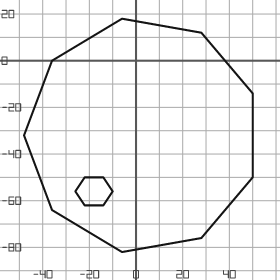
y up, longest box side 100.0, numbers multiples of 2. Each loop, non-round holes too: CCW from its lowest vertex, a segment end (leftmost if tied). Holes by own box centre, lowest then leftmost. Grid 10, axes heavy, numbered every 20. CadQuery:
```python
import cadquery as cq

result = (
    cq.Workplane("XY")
    .moveTo(-6.0, -82.0)
    .lineTo(28.0, -76.0)
    .lineTo(50.0, -50.0)
    .lineTo(50.0, -14.0)
    .lineTo(28.0, 12.0)
    .lineTo(-6.0, 18.0)
    .lineTo(-36.0, 0.0)
    .lineTo(-48.0, -32.0)
    .lineTo(-36.0, -64.0)
    .close()
    .moveTo(-22.0, -62.0)
    .lineTo(-14.0, -62.0)
    .lineTo(-10.0, -56.0)
    .lineTo(-14.0, -50.0)
    .lineTo(-22.0, -50.0)
    .lineTo(-26.0, -56.0)
    .close()
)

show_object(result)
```